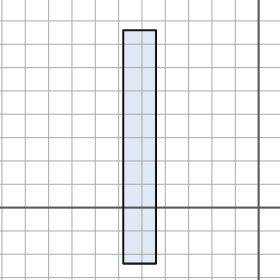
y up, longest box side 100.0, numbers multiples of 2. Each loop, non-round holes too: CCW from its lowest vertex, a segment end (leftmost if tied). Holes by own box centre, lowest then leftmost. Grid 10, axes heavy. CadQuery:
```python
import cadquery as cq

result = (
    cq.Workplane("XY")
    .moveTo(-58.0, -24.0)
    .lineTo(-44.0, -24.0)
    .lineTo(-44.0, 76.0)
    .lineTo(-58.0, 76.0)
    .close()
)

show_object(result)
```